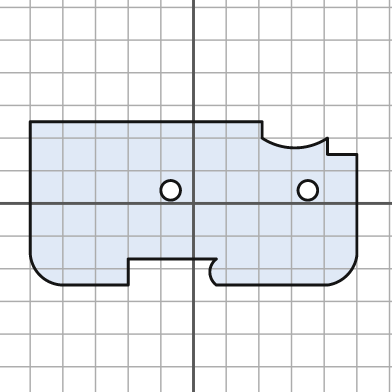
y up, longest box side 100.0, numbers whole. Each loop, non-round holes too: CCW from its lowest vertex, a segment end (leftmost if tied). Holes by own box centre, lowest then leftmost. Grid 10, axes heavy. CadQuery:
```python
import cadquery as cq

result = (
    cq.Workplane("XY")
    .moveTo(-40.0, -25.0)
    .lineTo(-20.0, -25.0)
    .lineTo(-20.0, -17.0)
    .lineTo(7.0, -17.0)
    .threePointArc((5.0, -21.0), (7.0, -25.0))
    .lineTo(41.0, -25.0)
    .threePointArc((47.0, -22.0), (50.0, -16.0))
    .lineTo(50.0, 15.0)
    .lineTo(41.0, 15.0)
    .lineTo(41.0, 20.0)
    .threePointArc((31.0, 17.0), (21.0, 20.0))
    .lineTo(21.0, 25.0)
    .lineTo(-50.0, 25.0)
    .lineTo(-50.0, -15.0)
    .threePointArc((-47.0, -22.0), (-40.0, -25.0))
    .close()
    .moveTo(-7.0, 4.0)
    .circle(3.0)
    .moveTo(35.0, 4.0)
    .circle(3.0)
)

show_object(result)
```